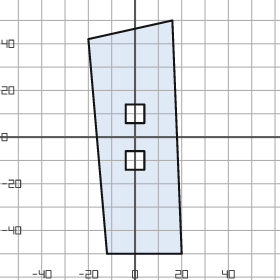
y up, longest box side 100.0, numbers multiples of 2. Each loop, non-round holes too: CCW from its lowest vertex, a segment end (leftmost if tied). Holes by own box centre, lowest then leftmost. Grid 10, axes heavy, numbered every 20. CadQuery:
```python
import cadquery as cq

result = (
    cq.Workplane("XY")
    .moveTo(-12.0, -50.0)
    .lineTo(20.0, -50.0)
    .lineTo(16.0, 50.0)
    .lineTo(-20.0, 42.0)
    .close()
    .moveTo(-4.0, -14.0)
    .lineTo(4.0, -14.0)
    .lineTo(4.0, -6.0)
    .lineTo(-4.0, -6.0)
    .close()
    .moveTo(-4.0, 6.0)
    .lineTo(4.0, 6.0)
    .lineTo(4.0, 14.0)
    .lineTo(-4.0, 14.0)
    .close()
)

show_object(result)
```